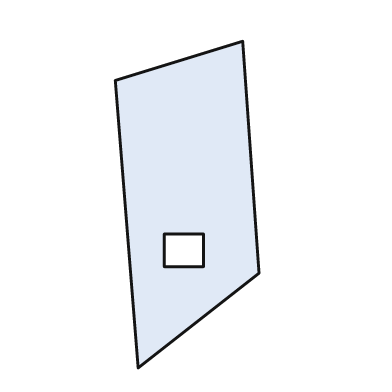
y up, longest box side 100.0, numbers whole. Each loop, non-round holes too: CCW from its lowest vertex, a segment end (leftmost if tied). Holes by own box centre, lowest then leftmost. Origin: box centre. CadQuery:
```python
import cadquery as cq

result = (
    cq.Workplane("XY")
    .moveTo(-15.0, -50.0)
    .lineTo(22.0, -21.0)
    .lineTo(17.0, 50.0)
    .lineTo(-22.0, 38.0)
    .close()
    .moveTo(-7.0, -19.0)
    .lineTo(5.0, -19.0)
    .lineTo(5.0, -9.0)
    .lineTo(-7.0, -9.0)
    .close()
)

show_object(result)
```